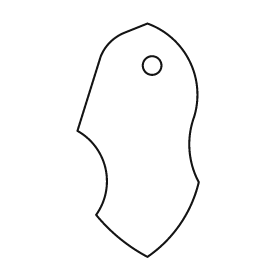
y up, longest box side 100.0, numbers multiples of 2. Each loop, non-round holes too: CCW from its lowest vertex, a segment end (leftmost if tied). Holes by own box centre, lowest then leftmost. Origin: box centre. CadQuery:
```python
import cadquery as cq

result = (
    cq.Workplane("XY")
    .moveTo(4.0, -50.0)
    .threePointArc((18.0, -36.0), (26.0, -18.0))
    .threePointArc((22.0, -4.0), (24.0, 10.0))
    .threePointArc((22.0, 34.0), (4.0, 50.0))
    .lineTo(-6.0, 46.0)
    .threePointArc((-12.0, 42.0), (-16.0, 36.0))
    .lineTo(-26.0, 4.0)
    .threePointArc((-14.0, -12.0), (-18.0, -32.0))
    .threePointArc((-8.0, -42.0), (4.0, -50.0))
    .close()
    .moveTo(6.0, 32.0)
    .circle(4.0)
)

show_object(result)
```